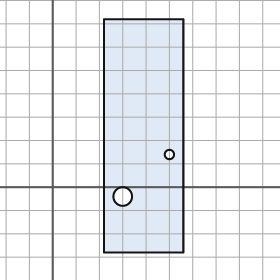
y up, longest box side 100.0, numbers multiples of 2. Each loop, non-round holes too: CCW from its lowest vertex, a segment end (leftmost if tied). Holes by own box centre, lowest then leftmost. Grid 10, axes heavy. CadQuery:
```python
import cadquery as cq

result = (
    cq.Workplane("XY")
    .moveTo(22.0, -28.0)
    .lineTo(56.0, -28.0)
    .lineTo(56.0, 72.0)
    .lineTo(22.0, 72.0)
    .close()
    .moveTo(30.0, -4.0)
    .circle(4.0)
    .moveTo(50.0, 14.0)
    .circle(2.0)
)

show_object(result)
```